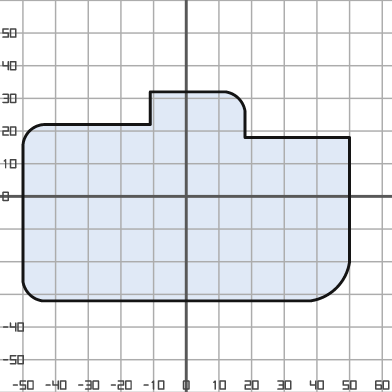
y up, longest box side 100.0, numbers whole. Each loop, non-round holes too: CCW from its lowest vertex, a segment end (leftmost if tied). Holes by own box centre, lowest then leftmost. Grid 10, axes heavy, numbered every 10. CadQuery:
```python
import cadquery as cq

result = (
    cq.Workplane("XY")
    .moveTo(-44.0, -32.0)
    .lineTo(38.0, -32.0)
    .threePointArc((46.0, -28.0), (50.0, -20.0))
    .lineTo(50.0, 18.0)
    .lineTo(18.0, 18.0)
    .lineTo(18.0, 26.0)
    .threePointArc((16.0, 30.0), (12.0, 32.0))
    .lineTo(-11.0, 32.0)
    .lineTo(-11.0, 22.0)
    .lineTo(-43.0, 22.0)
    .threePointArc((-48.0, 20.0), (-50.0, 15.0))
    .lineTo(-50.0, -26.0)
    .threePointArc((-48.0, -30.0), (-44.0, -32.0))
    .close()
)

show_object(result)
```